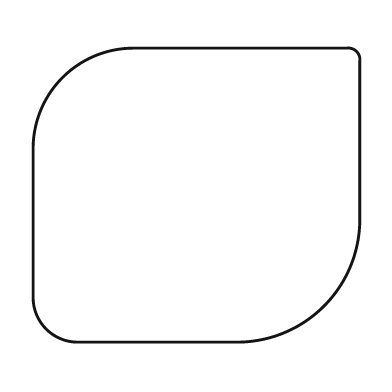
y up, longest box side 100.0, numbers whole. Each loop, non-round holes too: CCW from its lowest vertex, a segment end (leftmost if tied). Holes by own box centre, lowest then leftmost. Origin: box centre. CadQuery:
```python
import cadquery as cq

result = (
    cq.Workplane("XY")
    .moveTo(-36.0, -45.0)
    .lineTo(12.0, -45.0)
    .threePointArc((39.0, -34.0), (50.0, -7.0))
    .lineTo(50.0, 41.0)
    .threePointArc((49.0, 44.0), (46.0, 45.0))
    .lineTo(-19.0, 45.0)
    .threePointArc((-41.0, 36.0), (-50.0, 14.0))
    .lineTo(-50.0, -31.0)
    .threePointArc((-46.0, -41.0), (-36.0, -45.0))
    .close()
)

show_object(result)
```